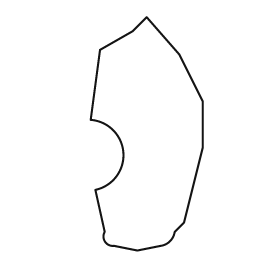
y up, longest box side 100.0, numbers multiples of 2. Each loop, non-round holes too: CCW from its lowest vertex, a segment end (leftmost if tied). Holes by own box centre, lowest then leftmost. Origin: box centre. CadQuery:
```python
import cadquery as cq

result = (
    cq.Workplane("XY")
    .moveTo(-4.0, -50.0)
    .lineTo(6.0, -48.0)
    .threePointArc((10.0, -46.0), (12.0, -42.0))
    .lineTo(16.0, -38.0)
    .lineTo(24.0, -6.0)
    .lineTo(24.0, 14.0)
    .lineTo(14.0, 34.0)
    .lineTo(0.0, 50.0)
    .lineTo(-6.0, 44.0)
    .lineTo(-20.0, 36.0)
    .lineTo(-24.0, 6.0)
    .threePointArc((-10.0, -8.0), (-22.0, -24.0))
    .lineTo(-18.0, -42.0)
    .threePointArc((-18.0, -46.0), (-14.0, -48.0))
    .close()
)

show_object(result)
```